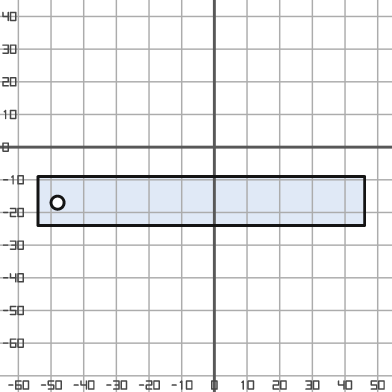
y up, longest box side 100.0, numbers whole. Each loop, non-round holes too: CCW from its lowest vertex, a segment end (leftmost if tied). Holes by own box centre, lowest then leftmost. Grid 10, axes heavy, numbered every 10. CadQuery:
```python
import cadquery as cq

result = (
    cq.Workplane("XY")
    .moveTo(-54.0, -24.0)
    .lineTo(46.0, -24.0)
    .lineTo(46.0, -9.0)
    .lineTo(-54.0, -9.0)
    .close()
    .moveTo(-48.0, -17.0)
    .circle(2.0)
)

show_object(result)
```